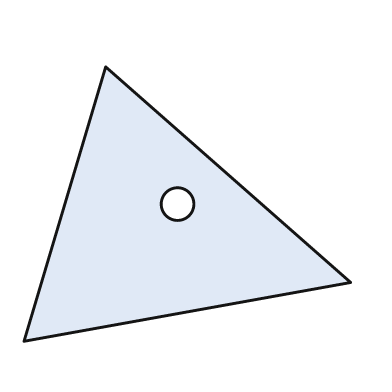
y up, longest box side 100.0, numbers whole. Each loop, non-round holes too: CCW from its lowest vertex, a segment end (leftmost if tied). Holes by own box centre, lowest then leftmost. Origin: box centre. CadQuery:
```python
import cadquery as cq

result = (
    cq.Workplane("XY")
    .moveTo(-50.0, -42.0)
    .lineTo(50.0, -24.0)
    .lineTo(-25.0, 42.0)
    .close()
    .moveTo(-3.0, 0.0)
    .circle(5.0)
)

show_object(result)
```